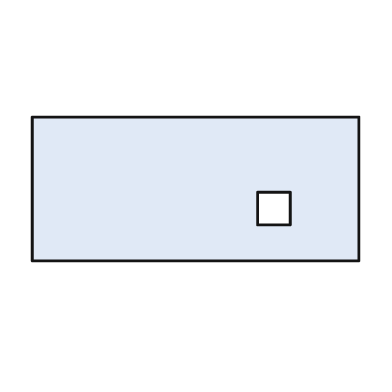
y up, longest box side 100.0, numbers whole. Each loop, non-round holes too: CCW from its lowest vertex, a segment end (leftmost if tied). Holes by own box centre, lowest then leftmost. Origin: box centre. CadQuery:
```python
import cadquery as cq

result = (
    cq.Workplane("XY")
    .moveTo(-50.0, -22.0)
    .lineTo(50.0, -22.0)
    .lineTo(50.0, 22.0)
    .lineTo(-50.0, 22.0)
    .close()
    .moveTo(19.0, -11.0)
    .lineTo(29.0, -11.0)
    .lineTo(29.0, -1.0)
    .lineTo(19.0, -1.0)
    .close()
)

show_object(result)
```